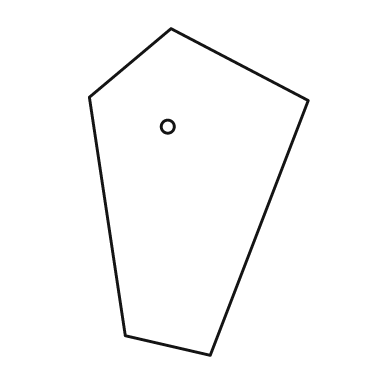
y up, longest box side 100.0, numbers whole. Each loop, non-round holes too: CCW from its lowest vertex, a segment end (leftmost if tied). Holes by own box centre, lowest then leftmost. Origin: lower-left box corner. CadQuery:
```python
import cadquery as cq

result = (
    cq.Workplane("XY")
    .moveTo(37.0, 0.0)
    .lineTo(67.0, 78.0)
    .lineTo(25.0, 100.0)
    .lineTo(0.0, 79.0)
    .lineTo(11.0, 6.0)
    .close()
    .moveTo(24.0, 70.0)
    .circle(2.0)
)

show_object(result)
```